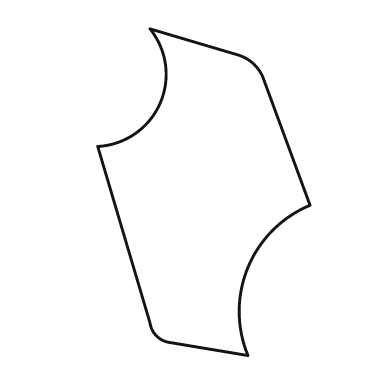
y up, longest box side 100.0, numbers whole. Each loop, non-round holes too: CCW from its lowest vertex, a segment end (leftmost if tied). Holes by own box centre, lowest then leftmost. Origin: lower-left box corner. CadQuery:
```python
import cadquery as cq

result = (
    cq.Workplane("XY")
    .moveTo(46.0, 0.0)
    .threePointArc((46.0, 27.0), (65.0, 46.0))
    .lineTo(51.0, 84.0)
    .threePointArc((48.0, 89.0), (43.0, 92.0))
    .lineTo(16.0, 100.0)
    .threePointArc((19.0, 77.0), (0.0, 64.0))
    .lineTo(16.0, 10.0)
    .threePointArc((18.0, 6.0), (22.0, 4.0))
    .close()
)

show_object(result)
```